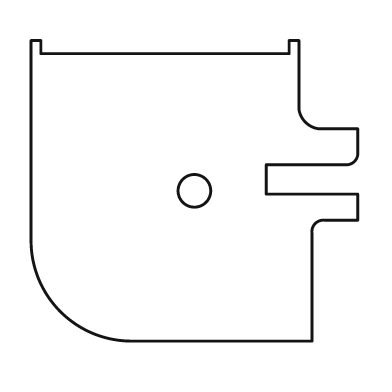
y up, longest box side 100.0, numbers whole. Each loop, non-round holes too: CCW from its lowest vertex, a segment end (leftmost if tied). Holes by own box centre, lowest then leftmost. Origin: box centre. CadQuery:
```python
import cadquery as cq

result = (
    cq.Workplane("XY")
    .moveTo(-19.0, -46.0)
    .lineTo(36.0, -46.0)
    .lineTo(36.0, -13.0)
    .threePointArc((37.0, -10.0), (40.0, -9.0))
    .lineTo(50.0, -9.0)
    .lineTo(50.0, -1.0)
    .lineTo(22.0, -1.0)
    .lineTo(22.0, 8.0)
    .lineTo(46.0, 8.0)
    .threePointArc((49.0, 9.0), (50.0, 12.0))
    .lineTo(50.0, 19.0)
    .lineTo(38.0, 19.0)
    .threePointArc((34.0, 21.0), (32.0, 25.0))
    .lineTo(32.0, 46.0)
    .lineTo(29.0, 46.0)
    .lineTo(29.0, 42.0)
    .lineTo(-47.0, 42.0)
    .lineTo(-47.0, 46.0)
    .lineTo(-50.0, 46.0)
    .lineTo(-50.0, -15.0)
    .threePointArc((-41.0, -37.0), (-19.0, -46.0))
    .close()
    .moveTo(0.0, 0.0)
    .circle(5.0)
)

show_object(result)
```